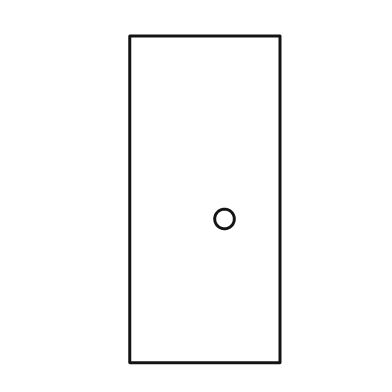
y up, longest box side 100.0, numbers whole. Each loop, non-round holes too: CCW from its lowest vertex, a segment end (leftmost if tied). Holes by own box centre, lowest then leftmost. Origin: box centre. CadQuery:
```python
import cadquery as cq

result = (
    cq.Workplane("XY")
    .moveTo(-23.0, -50.0)
    .lineTo(23.0, -50.0)
    .lineTo(23.0, 50.0)
    .lineTo(-23.0, 50.0)
    .close()
    .moveTo(6.0, -6.0)
    .circle(3.0)
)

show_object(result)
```